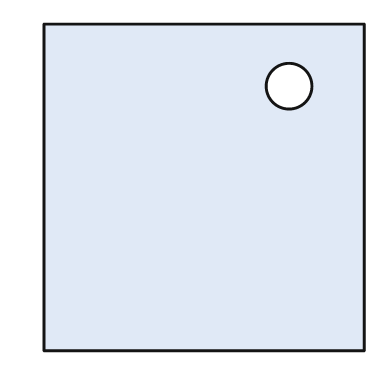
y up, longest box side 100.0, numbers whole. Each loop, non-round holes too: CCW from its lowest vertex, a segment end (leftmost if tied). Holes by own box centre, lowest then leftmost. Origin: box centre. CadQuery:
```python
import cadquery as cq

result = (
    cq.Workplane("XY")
    .moveTo(-49.0, -50.0)
    .lineTo(49.0, -50.0)
    .lineTo(49.0, 50.0)
    .lineTo(-49.0, 50.0)
    .close()
    .moveTo(26.0, 31.0)
    .circle(7.0)
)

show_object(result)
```